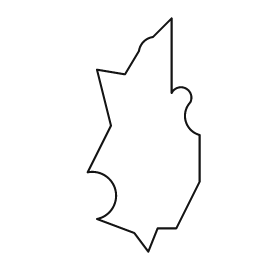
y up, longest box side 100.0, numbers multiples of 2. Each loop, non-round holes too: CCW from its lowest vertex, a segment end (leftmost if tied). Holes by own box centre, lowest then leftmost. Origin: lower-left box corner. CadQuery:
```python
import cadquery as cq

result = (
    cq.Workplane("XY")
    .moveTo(26.0, 0.0)
    .lineTo(30.0, 10.0)
    .lineTo(38.0, 10.0)
    .lineTo(48.0, 30.0)
    .lineTo(48.0, 50.0)
    .threePointArc((42.0, 56.0), (44.0, 64.0))
    .threePointArc((42.0, 70.0), (36.0, 68.0))
    .lineTo(36.0, 100.0)
    .lineTo(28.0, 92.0)
    .threePointArc((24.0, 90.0), (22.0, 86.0))
    .lineTo(16.0, 76.0)
    .lineTo(4.0, 78.0)
    .lineTo(10.0, 54.0)
    .lineTo(0.0, 34.0)
    .threePointArc((12.0, 26.0), (4.0, 14.0))
    .lineTo(20.0, 8.0)
    .close()
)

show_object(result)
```